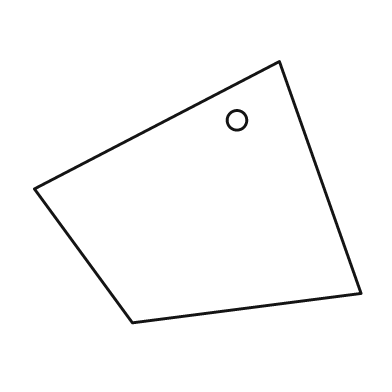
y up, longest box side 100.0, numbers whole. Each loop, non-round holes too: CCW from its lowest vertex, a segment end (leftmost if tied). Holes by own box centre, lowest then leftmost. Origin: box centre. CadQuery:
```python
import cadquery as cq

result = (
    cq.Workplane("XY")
    .moveTo(-20.0, -40.0)
    .lineTo(50.0, -31.0)
    .lineTo(25.0, 40.0)
    .lineTo(-50.0, 1.0)
    .close()
    .moveTo(12.0, 22.0)
    .circle(3.0)
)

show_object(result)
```